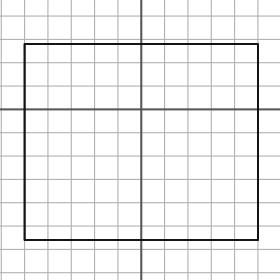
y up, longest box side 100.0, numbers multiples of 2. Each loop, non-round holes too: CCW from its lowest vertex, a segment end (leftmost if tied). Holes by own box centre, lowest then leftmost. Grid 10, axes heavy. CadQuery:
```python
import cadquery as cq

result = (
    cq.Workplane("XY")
    .moveTo(-50.0, -56.0)
    .lineTo(50.0, -56.0)
    .lineTo(50.0, 28.0)
    .lineTo(-50.0, 28.0)
    .close()
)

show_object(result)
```